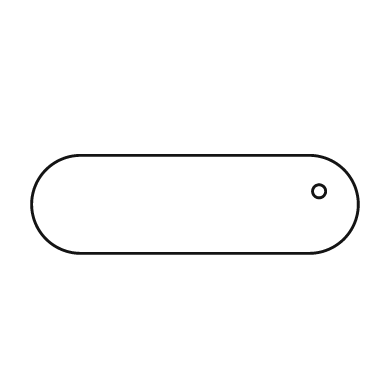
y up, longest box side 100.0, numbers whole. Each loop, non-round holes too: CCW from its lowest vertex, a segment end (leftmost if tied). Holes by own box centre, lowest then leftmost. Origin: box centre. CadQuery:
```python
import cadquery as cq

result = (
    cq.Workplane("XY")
    .moveTo(-35.0, -15.0)
    .lineTo(35.0, -15.0)
    .threePointArc((50.0, 0.0), (35.0, 15.0))
    .lineTo(-35.0, 15.0)
    .threePointArc((-50.0, 0.0), (-35.0, -15.0))
    .close()
    .moveTo(38.0, 4.0)
    .circle(2.0)
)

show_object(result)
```